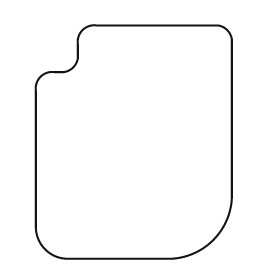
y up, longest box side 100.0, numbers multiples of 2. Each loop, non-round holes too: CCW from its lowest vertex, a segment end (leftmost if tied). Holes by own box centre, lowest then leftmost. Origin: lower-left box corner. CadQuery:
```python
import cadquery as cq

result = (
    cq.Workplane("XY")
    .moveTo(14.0, 0.0)
    .lineTo(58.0, 0.0)
    .threePointArc((76.0, 8.0), (84.0, 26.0))
    .lineTo(84.0, 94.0)
    .threePointArc((82.0, 98.0), (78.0, 100.0))
    .lineTo(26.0, 100.0)
    .threePointArc((20.0, 98.0), (18.0, 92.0))
    .lineTo(18.0, 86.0)
    .threePointArc((16.0, 82.0), (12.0, 80.0))
    .lineTo(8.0, 80.0)
    .threePointArc((2.0, 78.0), (0.0, 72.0))
    .lineTo(0.0, 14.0)
    .threePointArc((4.0, 4.0), (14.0, 0.0))
    .close()
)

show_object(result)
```